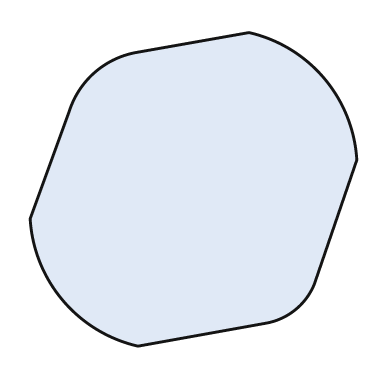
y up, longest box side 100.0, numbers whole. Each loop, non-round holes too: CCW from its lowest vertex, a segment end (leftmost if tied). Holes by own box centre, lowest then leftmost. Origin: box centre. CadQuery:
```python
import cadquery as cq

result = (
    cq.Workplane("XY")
    .moveTo(-17.0, -48.0)
    .lineTo(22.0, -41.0)
    .threePointArc((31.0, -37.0), (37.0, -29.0))
    .lineTo(50.0, 9.0)
    .threePointArc((40.0, 34.0), (17.0, 48.0))
    .lineTo(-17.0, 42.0)
    .threePointArc((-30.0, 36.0), (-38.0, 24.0))
    .lineTo(-50.0, -9.0)
    .threePointArc((-40.0, -34.0), (-17.0, -48.0))
    .close()
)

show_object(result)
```